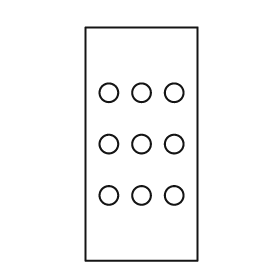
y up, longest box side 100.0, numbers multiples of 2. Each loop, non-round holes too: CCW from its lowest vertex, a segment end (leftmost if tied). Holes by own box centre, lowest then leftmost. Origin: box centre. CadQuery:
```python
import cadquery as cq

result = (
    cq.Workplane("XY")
    .moveTo(-24.0, -50.0)
    .lineTo(24.0, -50.0)
    .lineTo(24.0, 50.0)
    .lineTo(-24.0, 50.0)
    .close()
    .moveTo(-14.0, -22.0)
    .circle(4.0)
    .moveTo(0.0, -22.0)
    .circle(4.0)
    .moveTo(14.0, -22.0)
    .circle(4.0)
    .moveTo(-14.0, 0.0)
    .circle(4.0)
    .moveTo(0.0, 0.0)
    .circle(4.0)
    .moveTo(14.0, 0.0)
    .circle(4.0)
    .moveTo(-14.0, 22.0)
    .circle(4.0)
    .moveTo(0.0, 22.0)
    .circle(4.0)
    .moveTo(14.0, 22.0)
    .circle(4.0)
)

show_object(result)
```